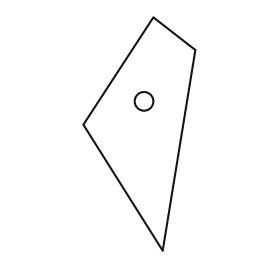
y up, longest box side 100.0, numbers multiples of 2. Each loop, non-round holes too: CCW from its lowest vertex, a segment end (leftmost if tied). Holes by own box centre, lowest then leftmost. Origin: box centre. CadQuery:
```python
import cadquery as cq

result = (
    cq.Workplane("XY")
    .moveTo(10.0, -50.0)
    .lineTo(24.0, 36.0)
    .lineTo(6.0, 50.0)
    .lineTo(-24.0, 4.0)
    .close()
    .moveTo(2.0, 14.0)
    .circle(4.0)
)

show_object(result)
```